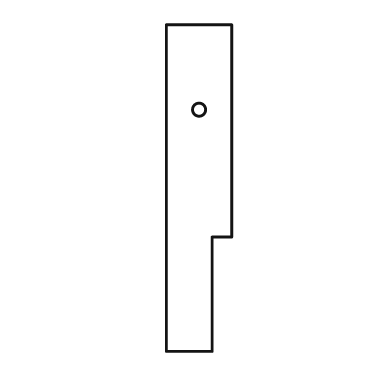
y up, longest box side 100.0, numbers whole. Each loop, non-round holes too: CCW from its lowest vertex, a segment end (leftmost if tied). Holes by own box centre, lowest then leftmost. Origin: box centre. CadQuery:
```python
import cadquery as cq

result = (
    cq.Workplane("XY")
    .moveTo(-10.0, -50.0)
    .lineTo(4.0, -50.0)
    .lineTo(4.0, -15.0)
    .lineTo(10.0, -15.0)
    .lineTo(10.0, 50.0)
    .lineTo(-10.0, 50.0)
    .close()
    .moveTo(0.0, 24.0)
    .circle(2.0)
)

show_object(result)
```